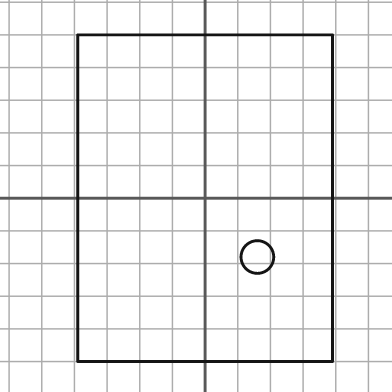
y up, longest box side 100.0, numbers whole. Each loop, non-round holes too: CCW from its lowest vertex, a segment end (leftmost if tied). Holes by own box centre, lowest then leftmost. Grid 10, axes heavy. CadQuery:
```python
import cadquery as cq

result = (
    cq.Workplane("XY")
    .moveTo(-39.0, -50.0)
    .lineTo(39.0, -50.0)
    .lineTo(39.0, 50.0)
    .lineTo(-39.0, 50.0)
    .close()
    .moveTo(16.0, -18.0)
    .circle(5.0)
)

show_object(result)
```